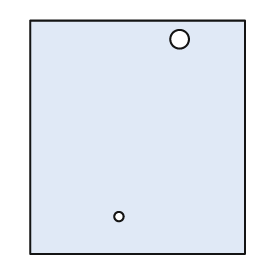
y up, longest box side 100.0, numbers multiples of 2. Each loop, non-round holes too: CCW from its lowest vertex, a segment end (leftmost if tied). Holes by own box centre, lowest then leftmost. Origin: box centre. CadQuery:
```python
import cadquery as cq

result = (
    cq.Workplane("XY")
    .moveTo(-46.0, -50.0)
    .lineTo(46.0, -50.0)
    .lineTo(46.0, 50.0)
    .lineTo(-46.0, 50.0)
    .close()
    .moveTo(-8.0, -34.0)
    .circle(2.0)
    .moveTo(18.0, 42.0)
    .circle(4.0)
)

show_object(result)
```